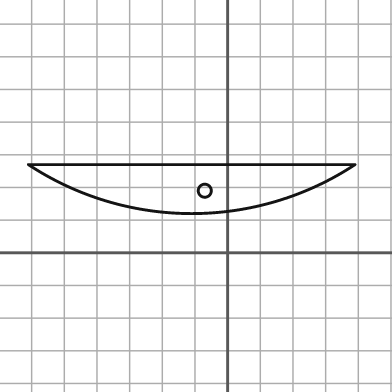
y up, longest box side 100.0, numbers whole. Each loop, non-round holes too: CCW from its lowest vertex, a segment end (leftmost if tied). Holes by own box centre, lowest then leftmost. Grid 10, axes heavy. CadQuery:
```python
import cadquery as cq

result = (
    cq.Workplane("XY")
    .moveTo(-61.0, 27.0)
    .threePointArc((-11.0, 12.0), (39.0, 27.0))
    .close()
    .moveTo(-7.0, 19.0)
    .circle(2.0)
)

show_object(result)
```